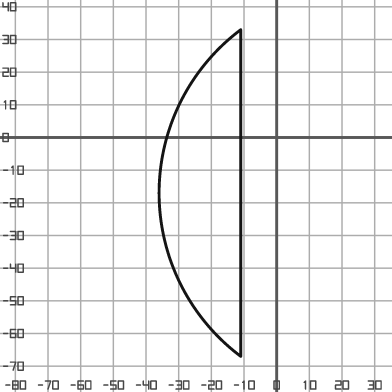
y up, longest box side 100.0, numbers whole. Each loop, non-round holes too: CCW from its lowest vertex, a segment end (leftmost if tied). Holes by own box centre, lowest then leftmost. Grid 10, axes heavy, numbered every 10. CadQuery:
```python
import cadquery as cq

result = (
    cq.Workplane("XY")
    .moveTo(-11.0, -67.0)
    .lineTo(-11.0, 33.0)
    .threePointArc((-36.0, -17.0), (-11.0, -67.0))
    .close()
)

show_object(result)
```